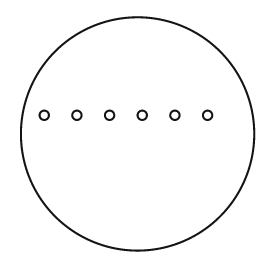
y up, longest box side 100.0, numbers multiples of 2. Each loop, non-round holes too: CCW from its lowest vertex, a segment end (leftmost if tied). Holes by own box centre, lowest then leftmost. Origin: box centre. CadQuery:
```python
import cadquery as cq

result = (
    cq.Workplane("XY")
    .moveTo(0.0, 0.0)
    .circle(50.0)
    .moveTo(-40.0, 8.0)
    .circle(2.0)
    .moveTo(-26.0, 8.0)
    .circle(2.0)
    .moveTo(-12.0, 8.0)
    .circle(2.0)
    .moveTo(2.0, 8.0)
    .circle(2.0)
    .moveTo(16.0, 8.0)
    .circle(2.0)
    .moveTo(30.0, 8.0)
    .circle(2.0)
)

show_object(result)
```